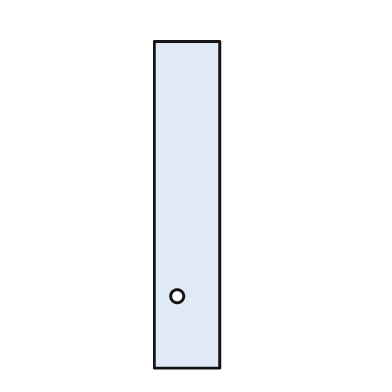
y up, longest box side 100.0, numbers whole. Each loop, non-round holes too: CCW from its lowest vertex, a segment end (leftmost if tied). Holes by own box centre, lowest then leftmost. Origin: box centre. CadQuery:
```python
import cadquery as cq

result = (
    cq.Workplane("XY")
    .moveTo(-10.0, -50.0)
    .lineTo(10.0, -50.0)
    .lineTo(10.0, 50.0)
    .lineTo(-10.0, 50.0)
    .close()
    .moveTo(-3.0, -28.0)
    .circle(2.0)
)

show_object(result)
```